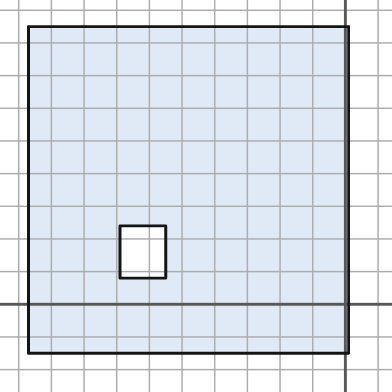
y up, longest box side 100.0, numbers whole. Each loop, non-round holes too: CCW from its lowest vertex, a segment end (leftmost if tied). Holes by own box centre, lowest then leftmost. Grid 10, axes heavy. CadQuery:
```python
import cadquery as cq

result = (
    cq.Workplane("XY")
    .moveTo(-97.0, -15.0)
    .lineTo(1.0, -15.0)
    .lineTo(1.0, 85.0)
    .lineTo(-97.0, 85.0)
    .close()
    .moveTo(-69.0, 8.0)
    .lineTo(-55.0, 8.0)
    .lineTo(-55.0, 24.0)
    .lineTo(-69.0, 24.0)
    .close()
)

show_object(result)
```